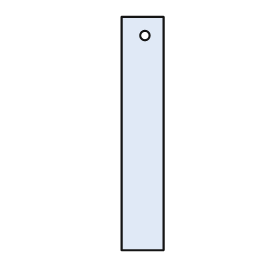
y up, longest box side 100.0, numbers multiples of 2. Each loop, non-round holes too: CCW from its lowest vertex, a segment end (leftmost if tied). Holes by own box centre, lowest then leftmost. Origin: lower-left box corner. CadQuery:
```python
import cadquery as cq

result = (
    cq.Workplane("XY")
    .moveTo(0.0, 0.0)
    .lineTo(18.0, 0.0)
    .lineTo(18.0, 100.0)
    .lineTo(0.0, 100.0)
    .close()
    .moveTo(10.0, 92.0)
    .circle(2.0)
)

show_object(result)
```